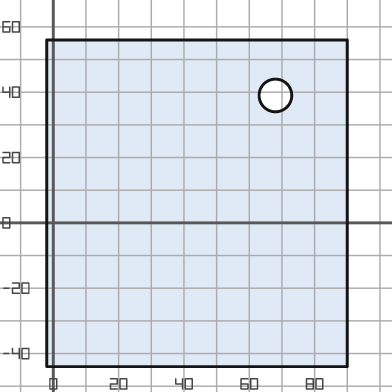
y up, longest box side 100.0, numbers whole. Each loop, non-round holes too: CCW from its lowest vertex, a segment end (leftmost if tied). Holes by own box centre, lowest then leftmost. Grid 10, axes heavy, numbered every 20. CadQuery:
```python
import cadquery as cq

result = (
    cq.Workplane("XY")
    .moveTo(-2.0, -44.0)
    .lineTo(90.0, -44.0)
    .lineTo(90.0, 56.0)
    .lineTo(-2.0, 56.0)
    .close()
    .moveTo(68.0, 39.0)
    .circle(5.0)
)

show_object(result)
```